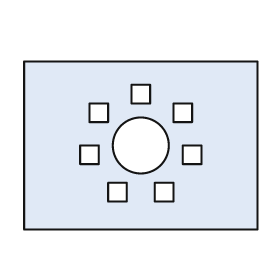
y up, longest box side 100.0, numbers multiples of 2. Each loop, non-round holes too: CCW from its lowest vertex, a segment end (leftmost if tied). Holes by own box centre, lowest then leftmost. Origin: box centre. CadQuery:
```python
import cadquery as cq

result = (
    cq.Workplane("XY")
    .moveTo(-50.0, -36.0)
    .lineTo(50.0, -36.0)
    .lineTo(50.0, 36.0)
    .lineTo(-50.0, 36.0)
    .close()
    .moveTo(-14.0, -24.0)
    .lineTo(-6.0, -24.0)
    .lineTo(-6.0, -16.0)
    .lineTo(-14.0, -16.0)
    .close()
    .moveTo(6.0, -24.0)
    .lineTo(14.0, -24.0)
    .lineTo(14.0, -16.0)
    .lineTo(6.0, -16.0)
    .close()
    .moveTo(-26.0, -8.0)
    .lineTo(-18.0, -8.0)
    .lineTo(-18.0, 0.0)
    .lineTo(-26.0, 0.0)
    .close()
    .moveTo(18.0, -8.0)
    .lineTo(26.0, -8.0)
    .lineTo(26.0, 0.0)
    .lineTo(18.0, 0.0)
    .close()
    .moveTo(0.0, 0.0)
    .circle(12.0)
    .moveTo(-22.0, 10.0)
    .lineTo(-14.0, 10.0)
    .lineTo(-14.0, 18.0)
    .lineTo(-22.0, 18.0)
    .close()
    .moveTo(14.0, 10.0)
    .lineTo(22.0, 10.0)
    .lineTo(22.0, 18.0)
    .lineTo(14.0, 18.0)
    .close()
    .moveTo(-4.0, 18.0)
    .lineTo(4.0, 18.0)
    .lineTo(4.0, 26.0)
    .lineTo(-4.0, 26.0)
    .close()
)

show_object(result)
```